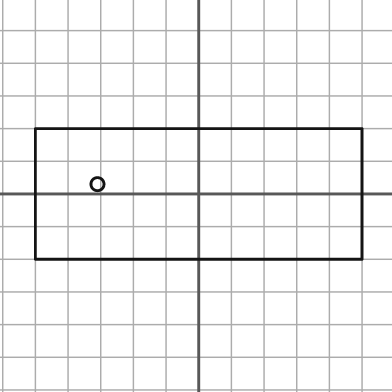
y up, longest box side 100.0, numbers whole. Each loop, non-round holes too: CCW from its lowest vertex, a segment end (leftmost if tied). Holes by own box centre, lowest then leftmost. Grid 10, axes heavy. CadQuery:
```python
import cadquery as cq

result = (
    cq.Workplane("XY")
    .moveTo(-50.0, -20.0)
    .lineTo(50.0, -20.0)
    .lineTo(50.0, 20.0)
    .lineTo(-50.0, 20.0)
    .close()
    .moveTo(-31.0, 3.0)
    .circle(2.0)
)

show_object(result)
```